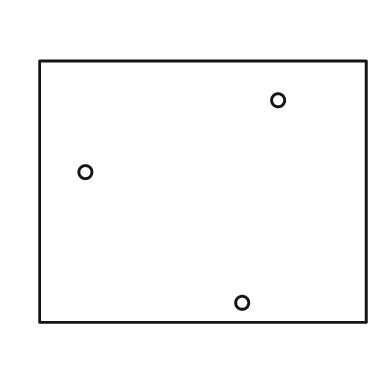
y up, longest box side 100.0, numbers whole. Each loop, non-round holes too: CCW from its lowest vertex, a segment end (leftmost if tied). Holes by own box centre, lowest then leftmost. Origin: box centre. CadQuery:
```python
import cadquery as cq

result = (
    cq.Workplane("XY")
    .moveTo(-50.0, -40.0)
    .lineTo(50.0, -40.0)
    .lineTo(50.0, 40.0)
    .lineTo(-50.0, 40.0)
    .close()
    .moveTo(12.0, -34.0)
    .circle(2.0)
    .moveTo(-36.0, 6.0)
    .circle(2.0)
    .moveTo(23.0, 28.0)
    .circle(2.0)
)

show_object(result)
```